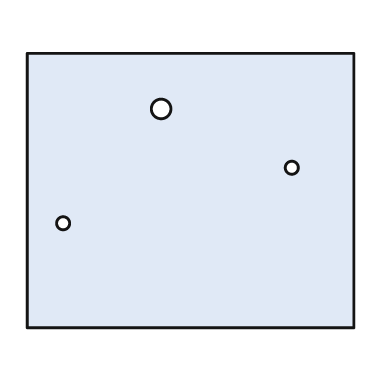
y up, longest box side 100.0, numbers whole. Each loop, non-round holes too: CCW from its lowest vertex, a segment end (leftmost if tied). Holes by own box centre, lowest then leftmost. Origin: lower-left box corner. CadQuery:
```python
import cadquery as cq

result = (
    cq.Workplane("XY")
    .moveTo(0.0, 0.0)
    .lineTo(100.0, 0.0)
    .lineTo(100.0, 84.0)
    .lineTo(0.0, 84.0)
    .close()
    .moveTo(11.0, 32.0)
    .circle(2.0)
    .moveTo(81.0, 49.0)
    .circle(2.0)
    .moveTo(41.0, 67.0)
    .circle(3.0)
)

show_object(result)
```